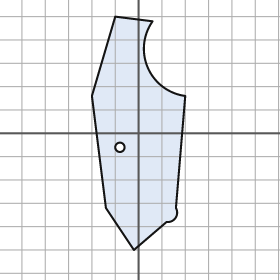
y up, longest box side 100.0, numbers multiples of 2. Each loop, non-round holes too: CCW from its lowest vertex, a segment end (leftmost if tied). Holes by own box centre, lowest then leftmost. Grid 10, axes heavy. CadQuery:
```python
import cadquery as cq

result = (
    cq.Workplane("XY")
    .moveTo(-2.0, -50.0)
    .lineTo(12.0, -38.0)
    .threePointArc((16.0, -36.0), (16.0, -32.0))
    .lineTo(20.0, 16.0)
    .threePointArc((4.0, 28.0), (6.0, 48.0))
    .lineTo(-10.0, 50.0)
    .lineTo(-20.0, 16.0)
    .lineTo(-14.0, -32.0)
    .close()
    .moveTo(-8.0, -6.0)
    .circle(2.0)
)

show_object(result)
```